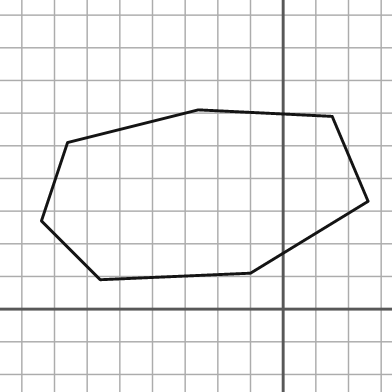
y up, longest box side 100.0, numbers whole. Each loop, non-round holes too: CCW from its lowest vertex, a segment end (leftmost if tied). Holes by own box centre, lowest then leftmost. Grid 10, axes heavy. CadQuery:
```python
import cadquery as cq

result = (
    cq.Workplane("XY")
    .moveTo(-56.0, 9.0)
    .lineTo(-10.0, 11.0)
    .lineTo(26.0, 33.0)
    .lineTo(15.0, 59.0)
    .lineTo(-26.0, 61.0)
    .lineTo(-66.0, 51.0)
    .lineTo(-74.0, 27.0)
    .close()
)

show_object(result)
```